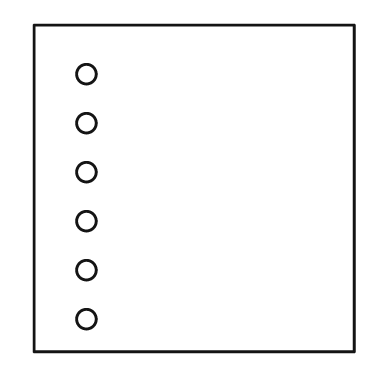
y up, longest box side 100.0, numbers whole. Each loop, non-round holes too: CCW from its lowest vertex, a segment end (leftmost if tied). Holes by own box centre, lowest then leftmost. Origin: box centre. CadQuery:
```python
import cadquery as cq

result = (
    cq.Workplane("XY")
    .moveTo(-49.0, -50.0)
    .lineTo(49.0, -50.0)
    .lineTo(49.0, 50.0)
    .lineTo(-49.0, 50.0)
    .close()
    .moveTo(-33.0, -40.0)
    .circle(3.0)
    .moveTo(-33.0, -25.0)
    .circle(3.0)
    .moveTo(-33.0, -10.0)
    .circle(3.0)
    .moveTo(-33.0, 5.0)
    .circle(3.0)
    .moveTo(-33.0, 20.0)
    .circle(3.0)
    .moveTo(-33.0, 35.0)
    .circle(3.0)
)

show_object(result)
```